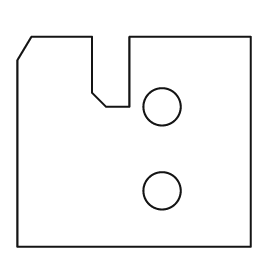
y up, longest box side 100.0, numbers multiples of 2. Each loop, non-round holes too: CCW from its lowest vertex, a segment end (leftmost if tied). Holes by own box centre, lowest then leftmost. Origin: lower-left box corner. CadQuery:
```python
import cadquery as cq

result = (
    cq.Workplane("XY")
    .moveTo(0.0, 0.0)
    .lineTo(100.0, 0.0)
    .lineTo(100.0, 90.0)
    .lineTo(48.0, 90.0)
    .lineTo(48.0, 60.0)
    .lineTo(38.0, 60.0)
    .lineTo(32.0, 66.0)
    .lineTo(32.0, 90.0)
    .lineTo(6.0, 90.0)
    .lineTo(0.0, 80.0)
    .close()
    .moveTo(62.0, 24.0)
    .circle(8.0)
    .moveTo(62.0, 60.0)
    .circle(8.0)
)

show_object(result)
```